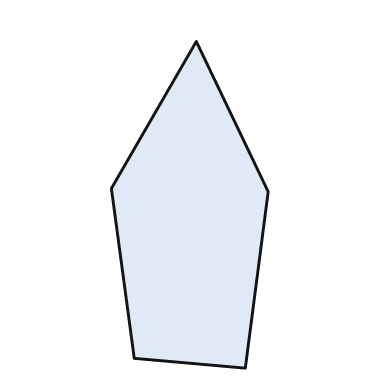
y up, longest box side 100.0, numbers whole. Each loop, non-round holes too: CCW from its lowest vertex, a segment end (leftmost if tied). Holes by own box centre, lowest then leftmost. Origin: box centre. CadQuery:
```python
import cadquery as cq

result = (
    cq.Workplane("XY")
    .moveTo(17.0, -50.0)
    .lineTo(24.0, 4.0)
    .lineTo(2.0, 50.0)
    .lineTo(-24.0, 5.0)
    .lineTo(-17.0, -47.0)
    .close()
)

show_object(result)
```